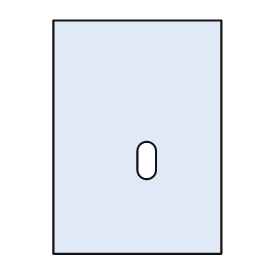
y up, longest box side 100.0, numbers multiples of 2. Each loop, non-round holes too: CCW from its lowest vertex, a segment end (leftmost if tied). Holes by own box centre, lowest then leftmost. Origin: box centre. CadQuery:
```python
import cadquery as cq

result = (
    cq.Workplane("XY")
    .moveTo(-36.0, -50.0)
    .lineTo(36.0, -50.0)
    .lineTo(36.0, 50.0)
    .lineTo(-36.0, 50.0)
    .close()
    .moveTo(0.0, -14.0)
    .threePointArc((4.0, -18.0), (8.0, -14.0))
    .lineTo(8.0, -6.0)
    .threePointArc((4.0, -2.0), (0.0, -6.0))
    .close()
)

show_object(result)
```